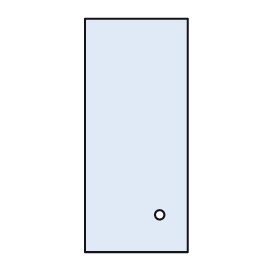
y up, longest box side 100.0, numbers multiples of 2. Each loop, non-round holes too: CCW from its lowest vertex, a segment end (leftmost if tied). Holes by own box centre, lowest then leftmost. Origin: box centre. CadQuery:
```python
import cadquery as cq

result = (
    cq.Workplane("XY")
    .moveTo(-22.0, -50.0)
    .lineTo(22.0, -50.0)
    .lineTo(22.0, 50.0)
    .lineTo(-22.0, 50.0)
    .close()
    .moveTo(10.0, -34.0)
    .circle(2.0)
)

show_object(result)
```